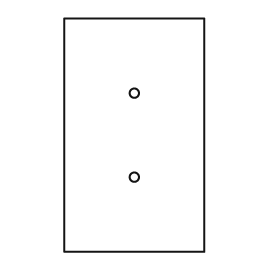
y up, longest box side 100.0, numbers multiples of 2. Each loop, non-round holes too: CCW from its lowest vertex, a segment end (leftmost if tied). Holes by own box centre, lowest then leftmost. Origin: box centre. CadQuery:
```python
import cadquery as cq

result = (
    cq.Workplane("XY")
    .moveTo(-30.0, -50.0)
    .lineTo(30.0, -50.0)
    .lineTo(30.0, 50.0)
    .lineTo(-30.0, 50.0)
    .close()
    .moveTo(0.0, -18.0)
    .circle(2.0)
    .moveTo(0.0, 18.0)
    .circle(2.0)
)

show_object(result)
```